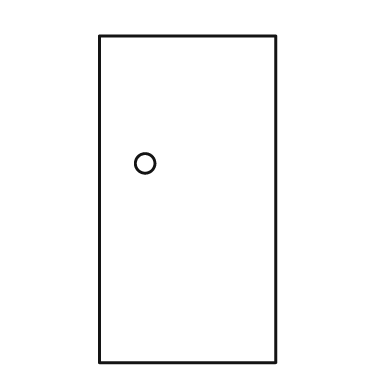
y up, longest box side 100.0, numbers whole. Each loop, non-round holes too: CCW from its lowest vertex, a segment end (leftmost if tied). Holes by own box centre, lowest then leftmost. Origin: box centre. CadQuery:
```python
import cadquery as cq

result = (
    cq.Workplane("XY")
    .moveTo(-27.0, -50.0)
    .lineTo(27.0, -50.0)
    .lineTo(27.0, 50.0)
    .lineTo(-27.0, 50.0)
    .close()
    .moveTo(-13.0, 11.0)
    .circle(3.0)
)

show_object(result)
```